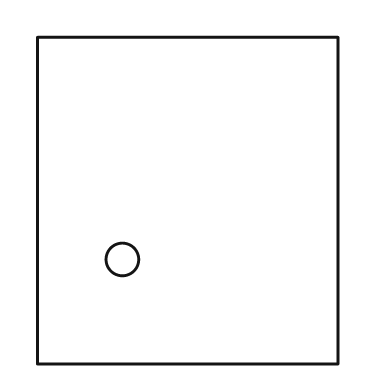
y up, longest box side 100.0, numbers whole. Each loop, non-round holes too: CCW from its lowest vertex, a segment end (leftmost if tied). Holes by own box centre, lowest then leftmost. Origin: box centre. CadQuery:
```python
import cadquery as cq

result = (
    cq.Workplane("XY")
    .moveTo(-46.0, -50.0)
    .lineTo(46.0, -50.0)
    .lineTo(46.0, 50.0)
    .lineTo(-46.0, 50.0)
    .close()
    .moveTo(-20.0, -18.0)
    .circle(5.0)
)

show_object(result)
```